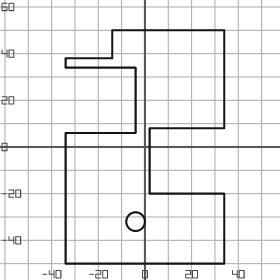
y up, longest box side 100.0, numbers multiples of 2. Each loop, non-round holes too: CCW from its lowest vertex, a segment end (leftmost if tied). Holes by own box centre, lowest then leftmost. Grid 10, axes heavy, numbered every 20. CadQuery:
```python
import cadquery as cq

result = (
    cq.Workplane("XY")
    .moveTo(-34.0, -50.0)
    .lineTo(34.0, -50.0)
    .lineTo(34.0, -20.0)
    .lineTo(2.0, -20.0)
    .lineTo(2.0, 8.0)
    .lineTo(34.0, 8.0)
    .lineTo(34.0, 50.0)
    .lineTo(-14.0, 50.0)
    .lineTo(-14.0, 38.0)
    .lineTo(-34.0, 38.0)
    .lineTo(-34.0, 34.0)
    .lineTo(-4.0, 34.0)
    .lineTo(-4.0, 6.0)
    .lineTo(-34.0, 6.0)
    .close()
    .moveTo(-4.0, -32.0)
    .circle(4.0)
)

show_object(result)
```